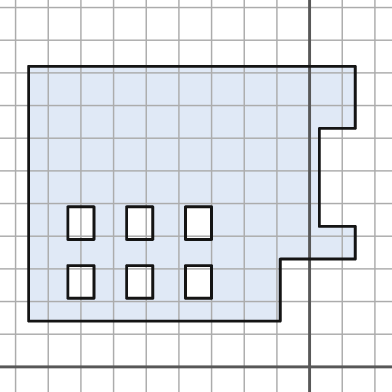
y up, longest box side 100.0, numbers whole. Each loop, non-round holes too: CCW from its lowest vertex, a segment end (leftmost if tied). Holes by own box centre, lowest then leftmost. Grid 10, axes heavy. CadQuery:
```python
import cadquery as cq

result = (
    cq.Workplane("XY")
    .moveTo(-86.0, 14.0)
    .lineTo(-9.0, 14.0)
    .lineTo(-9.0, 33.0)
    .lineTo(14.0, 33.0)
    .lineTo(14.0, 43.0)
    .lineTo(3.0, 43.0)
    .lineTo(3.0, 73.0)
    .lineTo(14.0, 73.0)
    .lineTo(14.0, 92.0)
    .lineTo(-86.0, 92.0)
    .close()
    .moveTo(-74.0, 21.0)
    .lineTo(-66.0, 21.0)
    .lineTo(-66.0, 31.0)
    .lineTo(-74.0, 31.0)
    .close()
    .moveTo(-56.0, 21.0)
    .lineTo(-48.0, 21.0)
    .lineTo(-48.0, 31.0)
    .lineTo(-56.0, 31.0)
    .close()
    .moveTo(-38.0, 21.0)
    .lineTo(-30.0, 21.0)
    .lineTo(-30.0, 31.0)
    .lineTo(-38.0, 31.0)
    .close()
    .moveTo(-74.0, 39.0)
    .lineTo(-66.0, 39.0)
    .lineTo(-66.0, 49.0)
    .lineTo(-74.0, 49.0)
    .close()
    .moveTo(-56.0, 39.0)
    .lineTo(-48.0, 39.0)
    .lineTo(-48.0, 49.0)
    .lineTo(-56.0, 49.0)
    .close()
    .moveTo(-38.0, 39.0)
    .lineTo(-30.0, 39.0)
    .lineTo(-30.0, 49.0)
    .lineTo(-38.0, 49.0)
    .close()
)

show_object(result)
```